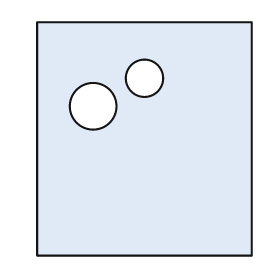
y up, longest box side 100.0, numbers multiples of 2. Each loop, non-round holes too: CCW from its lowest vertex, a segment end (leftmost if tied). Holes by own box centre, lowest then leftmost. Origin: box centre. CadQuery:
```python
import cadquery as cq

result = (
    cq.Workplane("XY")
    .moveTo(-46.0, -50.0)
    .lineTo(46.0, -50.0)
    .lineTo(46.0, 50.0)
    .lineTo(-46.0, 50.0)
    .close()
    .moveTo(-22.0, 14.0)
    .circle(10.0)
    .moveTo(0.0, 26.0)
    .circle(8.0)
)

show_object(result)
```